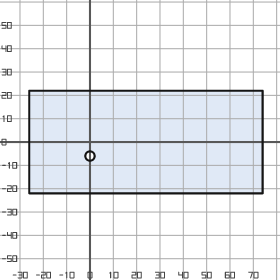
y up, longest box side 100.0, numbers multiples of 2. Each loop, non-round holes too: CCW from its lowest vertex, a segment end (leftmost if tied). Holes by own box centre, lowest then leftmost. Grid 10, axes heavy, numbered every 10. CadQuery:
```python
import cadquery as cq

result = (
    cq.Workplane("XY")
    .moveTo(-26.0, -22.0)
    .lineTo(74.0, -22.0)
    .lineTo(74.0, 22.0)
    .lineTo(-26.0, 22.0)
    .close()
    .moveTo(0.0, -6.0)
    .circle(2.0)
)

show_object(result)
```